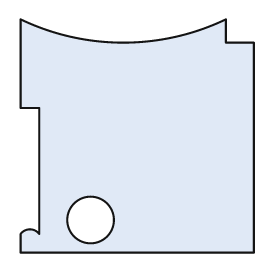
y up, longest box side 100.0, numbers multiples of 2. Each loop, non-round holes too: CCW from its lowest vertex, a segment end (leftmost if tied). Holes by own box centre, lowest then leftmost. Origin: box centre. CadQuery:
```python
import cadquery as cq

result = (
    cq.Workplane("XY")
    .moveTo(-50.0, -50.0)
    .lineTo(50.0, -50.0)
    .lineTo(50.0, 40.0)
    .lineTo(38.0, 40.0)
    .lineTo(38.0, 50.0)
    .threePointArc((-6.0, 40.0), (-50.0, 50.0))
    .lineTo(-50.0, 12.0)
    .lineTo(-42.0, 12.0)
    .lineTo(-42.0, -42.0)
    .threePointArc((-46.0, -40.0), (-50.0, -42.0))
    .close()
    .moveTo(-20.0, -36.0)
    .circle(10.0)
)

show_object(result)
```